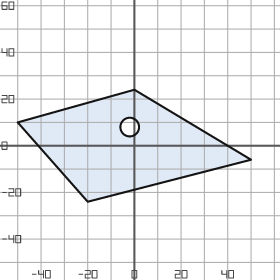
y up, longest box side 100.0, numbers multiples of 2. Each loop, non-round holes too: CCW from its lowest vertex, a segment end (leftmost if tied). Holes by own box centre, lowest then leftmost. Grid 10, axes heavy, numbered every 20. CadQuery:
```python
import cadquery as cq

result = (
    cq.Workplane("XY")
    .moveTo(-20.0, -24.0)
    .lineTo(50.0, -6.0)
    .lineTo(0.0, 24.0)
    .lineTo(-50.0, 10.0)
    .close()
    .moveTo(-2.0, 8.0)
    .circle(4.0)
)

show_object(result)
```